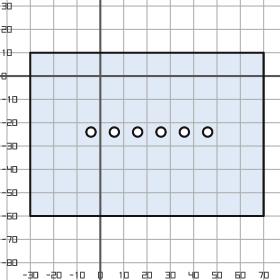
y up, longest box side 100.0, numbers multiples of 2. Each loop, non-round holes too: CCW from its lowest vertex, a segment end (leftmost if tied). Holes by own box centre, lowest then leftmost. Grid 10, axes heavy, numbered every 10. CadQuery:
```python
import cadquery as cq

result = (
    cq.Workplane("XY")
    .moveTo(-30.0, -60.0)
    .lineTo(70.0, -60.0)
    .lineTo(70.0, 10.0)
    .lineTo(-30.0, 10.0)
    .close()
    .moveTo(-4.0, -24.0)
    .circle(2.0)
    .moveTo(6.0, -24.0)
    .circle(2.0)
    .moveTo(16.0, -24.0)
    .circle(2.0)
    .moveTo(26.0, -24.0)
    .circle(2.0)
    .moveTo(36.0, -24.0)
    .circle(2.0)
    .moveTo(46.0, -24.0)
    .circle(2.0)
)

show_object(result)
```